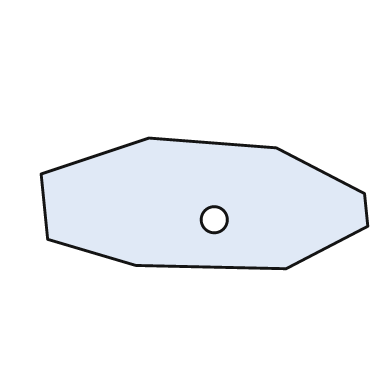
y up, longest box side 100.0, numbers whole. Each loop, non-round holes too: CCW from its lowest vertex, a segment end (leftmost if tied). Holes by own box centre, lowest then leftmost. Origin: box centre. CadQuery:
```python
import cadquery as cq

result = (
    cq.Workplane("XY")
    .moveTo(25.0, -20.0)
    .lineTo(50.0, -7.0)
    .lineTo(49.0, 3.0)
    .lineTo(22.0, 17.0)
    .lineTo(-17.0, 20.0)
    .lineTo(-50.0, 9.0)
    .lineTo(-48.0, -11.0)
    .lineTo(-21.0, -19.0)
    .close()
    .moveTo(3.0, -5.0)
    .circle(4.0)
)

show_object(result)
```